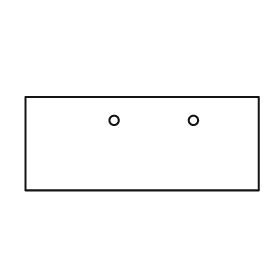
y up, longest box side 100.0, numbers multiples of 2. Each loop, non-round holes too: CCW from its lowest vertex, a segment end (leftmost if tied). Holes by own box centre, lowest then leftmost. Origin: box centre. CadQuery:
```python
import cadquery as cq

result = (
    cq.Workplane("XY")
    .moveTo(-50.0, -20.0)
    .lineTo(50.0, -20.0)
    .lineTo(50.0, 20.0)
    .lineTo(-50.0, 20.0)
    .close()
    .moveTo(-12.0, 10.0)
    .circle(2.0)
    .moveTo(22.0, 10.0)
    .circle(2.0)
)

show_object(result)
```